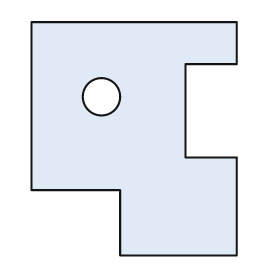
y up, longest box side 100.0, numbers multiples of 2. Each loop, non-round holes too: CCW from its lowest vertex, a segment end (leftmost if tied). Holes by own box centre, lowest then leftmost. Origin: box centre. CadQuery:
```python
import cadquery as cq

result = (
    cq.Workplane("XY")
    .moveTo(-6.0, -50.0)
    .lineTo(44.0, -50.0)
    .lineTo(44.0, -8.0)
    .lineTo(22.0, -8.0)
    .lineTo(22.0, 32.0)
    .lineTo(44.0, 32.0)
    .lineTo(44.0, 50.0)
    .lineTo(-44.0, 50.0)
    .lineTo(-44.0, -22.0)
    .lineTo(-6.0, -22.0)
    .close()
    .moveTo(-14.0, 18.0)
    .circle(8.0)
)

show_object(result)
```